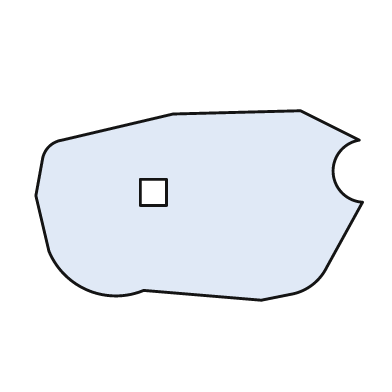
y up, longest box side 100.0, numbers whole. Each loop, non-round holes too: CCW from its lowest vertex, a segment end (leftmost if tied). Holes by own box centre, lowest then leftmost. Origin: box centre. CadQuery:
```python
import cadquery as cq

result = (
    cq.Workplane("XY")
    .moveTo(19.0, -29.0)
    .lineTo(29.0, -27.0)
    .threePointArc((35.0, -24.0), (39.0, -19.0))
    .lineTo(50.0, 1.0)
    .threePointArc((41.0, 10.0), (49.0, 20.0))
    .lineTo(31.0, 29.0)
    .lineTo(-8.0, 28.0)
    .lineTo(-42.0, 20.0)
    .threePointArc((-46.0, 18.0), (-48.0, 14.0))
    .lineTo(-50.0, 3.0)
    .lineTo(-46.0, -14.0)
    .threePointArc((-34.0, -26.0), (-17.0, -26.0))
    .close()
    .moveTo(-18.0, 0.0)
    .lineTo(-10.0, 0.0)
    .lineTo(-10.0, 8.0)
    .lineTo(-18.0, 8.0)
    .close()
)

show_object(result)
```